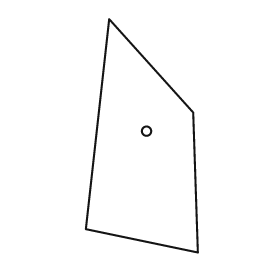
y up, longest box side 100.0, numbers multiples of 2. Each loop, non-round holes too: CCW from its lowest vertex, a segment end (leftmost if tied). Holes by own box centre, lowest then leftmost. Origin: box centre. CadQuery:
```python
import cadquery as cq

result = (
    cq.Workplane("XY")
    .moveTo(24.0, -50.0)
    .lineTo(22.0, 10.0)
    .lineTo(-14.0, 50.0)
    .lineTo(-24.0, -40.0)
    .close()
    .moveTo(2.0, 2.0)
    .circle(2.0)
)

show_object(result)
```